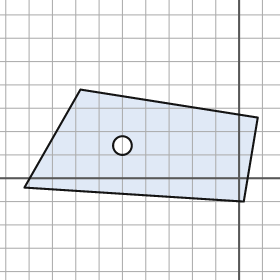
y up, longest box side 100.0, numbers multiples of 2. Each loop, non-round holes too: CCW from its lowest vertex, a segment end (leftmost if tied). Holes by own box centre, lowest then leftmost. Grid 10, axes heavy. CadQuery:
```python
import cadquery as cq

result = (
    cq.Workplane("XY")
    .moveTo(2.0, -10.0)
    .lineTo(8.0, 26.0)
    .lineTo(-68.0, 38.0)
    .lineTo(-92.0, -4.0)
    .close()
    .moveTo(-50.0, 14.0)
    .circle(4.0)
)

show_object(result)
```